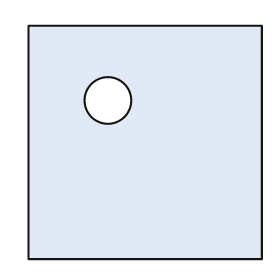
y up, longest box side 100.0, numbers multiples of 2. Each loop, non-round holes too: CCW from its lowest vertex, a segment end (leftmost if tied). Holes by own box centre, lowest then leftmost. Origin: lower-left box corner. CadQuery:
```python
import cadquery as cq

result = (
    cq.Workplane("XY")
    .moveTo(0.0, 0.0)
    .lineTo(100.0, 0.0)
    .lineTo(100.0, 100.0)
    .lineTo(0.0, 100.0)
    .close()
    .moveTo(34.0, 68.0)
    .circle(10.0)
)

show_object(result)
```